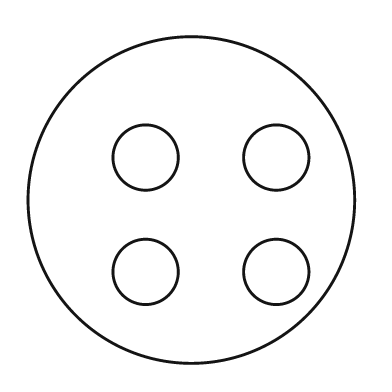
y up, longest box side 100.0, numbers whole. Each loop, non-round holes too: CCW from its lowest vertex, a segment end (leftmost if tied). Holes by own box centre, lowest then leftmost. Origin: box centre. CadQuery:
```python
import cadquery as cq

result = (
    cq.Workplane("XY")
    .moveTo(0.0, 0.0)
    .circle(50.0)
    .moveTo(-14.0, -22.0)
    .circle(10.0)
    .moveTo(26.0, -22.0)
    .circle(10.0)
    .moveTo(-14.0, 13.0)
    .circle(10.0)
    .moveTo(26.0, 13.0)
    .circle(10.0)
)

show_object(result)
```